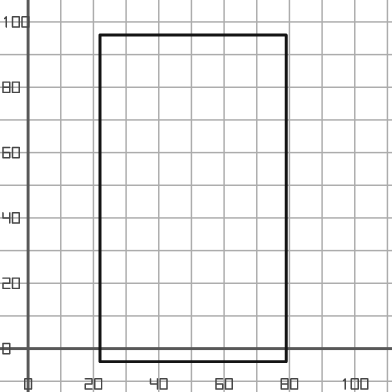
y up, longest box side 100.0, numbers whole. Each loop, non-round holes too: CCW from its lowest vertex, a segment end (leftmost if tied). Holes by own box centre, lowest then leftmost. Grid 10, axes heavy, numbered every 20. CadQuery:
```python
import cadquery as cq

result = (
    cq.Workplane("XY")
    .moveTo(22.0, -4.0)
    .lineTo(79.0, -4.0)
    .lineTo(79.0, 96.0)
    .lineTo(22.0, 96.0)
    .close()
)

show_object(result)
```